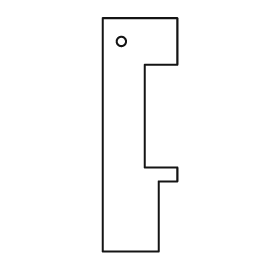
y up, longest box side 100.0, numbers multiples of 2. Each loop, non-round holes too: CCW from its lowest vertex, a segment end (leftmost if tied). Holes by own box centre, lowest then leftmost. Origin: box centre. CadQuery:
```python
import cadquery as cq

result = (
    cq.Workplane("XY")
    .moveTo(-16.0, -50.0)
    .lineTo(8.0, -50.0)
    .lineTo(8.0, -20.0)
    .lineTo(16.0, -20.0)
    .lineTo(16.0, -14.0)
    .lineTo(2.0, -14.0)
    .lineTo(2.0, 30.0)
    .lineTo(16.0, 30.0)
    .lineTo(16.0, 50.0)
    .lineTo(-16.0, 50.0)
    .close()
    .moveTo(-8.0, 40.0)
    .circle(2.0)
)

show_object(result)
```